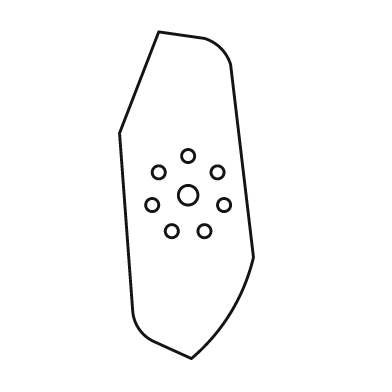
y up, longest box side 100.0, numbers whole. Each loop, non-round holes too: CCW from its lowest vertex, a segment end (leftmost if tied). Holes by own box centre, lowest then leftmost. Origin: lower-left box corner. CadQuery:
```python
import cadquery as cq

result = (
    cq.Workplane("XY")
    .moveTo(22.0, 0.0)
    .threePointArc((34.0, 14.0), (41.0, 31.0))
    .lineTo(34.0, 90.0)
    .threePointArc((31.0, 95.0), (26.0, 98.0))
    .lineTo(12.0, 100.0)
    .lineTo(0.0, 69.0)
    .lineTo(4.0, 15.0)
    .threePointArc((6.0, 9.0), (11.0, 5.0))
    .close()
    .moveTo(16.0, 39.0)
    .circle(2.0)
    .moveTo(26.0, 39.0)
    .circle(2.0)
    .moveTo(10.0, 47.0)
    .circle(2.0)
    .moveTo(32.0, 47.0)
    .circle(2.0)
    .moveTo(21.0, 50.0)
    .circle(3.0)
    .moveTo(12.0, 57.0)
    .circle(2.0)
    .moveTo(30.0, 57.0)
    .circle(2.0)
    .moveTo(21.0, 62.0)
    .circle(2.0)
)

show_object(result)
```